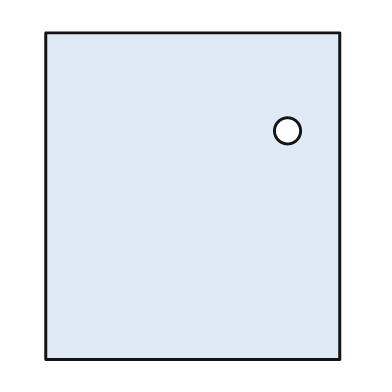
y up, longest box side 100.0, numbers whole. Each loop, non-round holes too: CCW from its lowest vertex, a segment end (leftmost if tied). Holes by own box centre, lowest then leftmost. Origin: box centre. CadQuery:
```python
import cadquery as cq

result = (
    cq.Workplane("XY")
    .moveTo(-45.0, -50.0)
    .lineTo(45.0, -50.0)
    .lineTo(45.0, 50.0)
    .lineTo(-45.0, 50.0)
    .close()
    .moveTo(29.0, 20.0)
    .circle(4.0)
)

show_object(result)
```